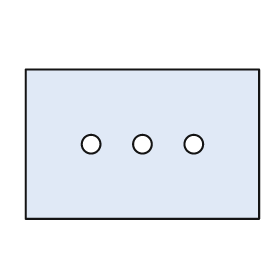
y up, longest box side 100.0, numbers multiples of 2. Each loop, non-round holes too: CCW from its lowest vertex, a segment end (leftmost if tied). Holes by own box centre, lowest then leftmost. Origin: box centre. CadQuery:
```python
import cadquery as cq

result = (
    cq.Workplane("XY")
    .moveTo(-50.0, -32.0)
    .lineTo(50.0, -32.0)
    .lineTo(50.0, 32.0)
    .lineTo(-50.0, 32.0)
    .close()
    .moveTo(-22.0, 0.0)
    .circle(4.0)
    .moveTo(0.0, 0.0)
    .circle(4.0)
    .moveTo(22.0, 0.0)
    .circle(4.0)
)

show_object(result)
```